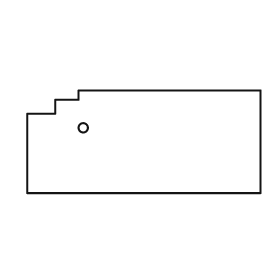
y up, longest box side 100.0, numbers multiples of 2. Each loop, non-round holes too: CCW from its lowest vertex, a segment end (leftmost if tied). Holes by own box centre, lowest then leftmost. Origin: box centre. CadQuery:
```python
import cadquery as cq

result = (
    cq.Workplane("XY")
    .moveTo(-50.0, -22.0)
    .lineTo(50.0, -22.0)
    .lineTo(50.0, 22.0)
    .lineTo(-28.0, 22.0)
    .lineTo(-28.0, 18.0)
    .lineTo(-38.0, 18.0)
    .lineTo(-38.0, 12.0)
    .lineTo(-50.0, 12.0)
    .close()
    .moveTo(-26.0, 6.0)
    .circle(2.0)
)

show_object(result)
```